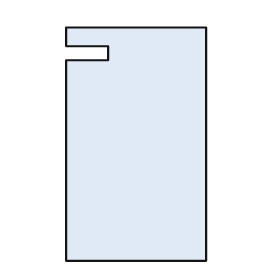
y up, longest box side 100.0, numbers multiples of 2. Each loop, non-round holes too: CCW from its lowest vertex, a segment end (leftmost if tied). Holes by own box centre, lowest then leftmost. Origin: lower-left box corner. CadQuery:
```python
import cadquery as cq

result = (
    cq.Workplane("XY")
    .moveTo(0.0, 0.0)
    .lineTo(60.0, 0.0)
    .lineTo(60.0, 100.0)
    .lineTo(0.0, 100.0)
    .lineTo(0.0, 92.0)
    .lineTo(18.0, 92.0)
    .lineTo(18.0, 86.0)
    .lineTo(0.0, 86.0)
    .close()
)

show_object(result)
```